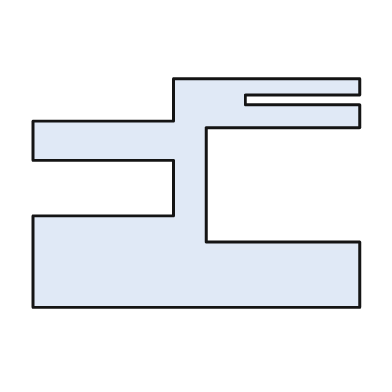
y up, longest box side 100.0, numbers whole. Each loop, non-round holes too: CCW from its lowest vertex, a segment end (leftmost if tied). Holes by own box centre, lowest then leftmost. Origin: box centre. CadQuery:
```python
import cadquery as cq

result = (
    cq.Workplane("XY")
    .moveTo(-50.0, -35.0)
    .lineTo(50.0, -35.0)
    .lineTo(50.0, -15.0)
    .lineTo(3.0, -15.0)
    .lineTo(3.0, 20.0)
    .lineTo(50.0, 20.0)
    .lineTo(50.0, 27.0)
    .lineTo(15.0, 27.0)
    .lineTo(15.0, 30.0)
    .lineTo(50.0, 30.0)
    .lineTo(50.0, 35.0)
    .lineTo(-7.0, 35.0)
    .lineTo(-7.0, 22.0)
    .lineTo(-50.0, 22.0)
    .lineTo(-50.0, 10.0)
    .lineTo(-7.0, 10.0)
    .lineTo(-7.0, -7.0)
    .lineTo(-50.0, -7.0)
    .close()
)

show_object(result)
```